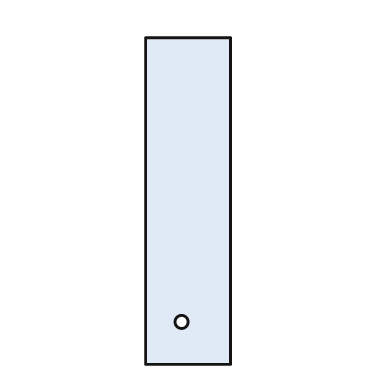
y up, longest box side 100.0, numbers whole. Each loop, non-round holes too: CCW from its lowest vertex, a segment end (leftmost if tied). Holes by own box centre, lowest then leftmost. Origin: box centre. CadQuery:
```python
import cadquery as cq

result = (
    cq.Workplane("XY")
    .moveTo(-13.0, -50.0)
    .lineTo(13.0, -50.0)
    .lineTo(13.0, 50.0)
    .lineTo(-13.0, 50.0)
    .close()
    .moveTo(-2.0, -37.0)
    .circle(2.0)
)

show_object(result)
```